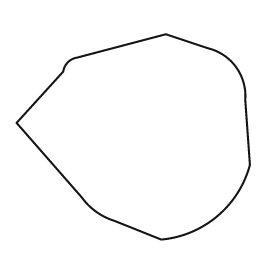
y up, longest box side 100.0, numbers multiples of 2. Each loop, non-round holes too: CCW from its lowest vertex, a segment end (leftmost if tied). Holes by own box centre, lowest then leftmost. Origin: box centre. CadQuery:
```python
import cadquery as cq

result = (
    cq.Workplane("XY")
    .moveTo(12.0, -44.0)
    .threePointArc((36.0, -34.0), (50.0, -12.0))
    .lineTo(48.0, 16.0)
    .threePointArc((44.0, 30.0), (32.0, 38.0))
    .lineTo(14.0, 44.0)
    .lineTo(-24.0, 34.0)
    .threePointArc((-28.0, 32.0), (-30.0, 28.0))
    .lineTo(-50.0, 6.0)
    .lineTo(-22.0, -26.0)
    .threePointArc((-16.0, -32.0), (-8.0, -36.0))
    .close()
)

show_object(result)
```